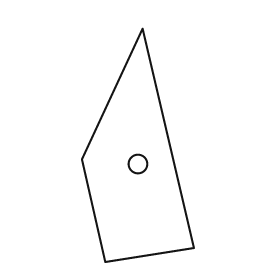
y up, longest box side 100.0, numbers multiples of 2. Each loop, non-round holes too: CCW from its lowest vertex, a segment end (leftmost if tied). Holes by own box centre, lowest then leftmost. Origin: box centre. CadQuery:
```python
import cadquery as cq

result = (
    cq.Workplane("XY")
    .moveTo(-14.0, -50.0)
    .lineTo(24.0, -44.0)
    .lineTo(2.0, 50.0)
    .lineTo(-24.0, -6.0)
    .close()
    .moveTo(0.0, -8.0)
    .circle(4.0)
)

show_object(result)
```